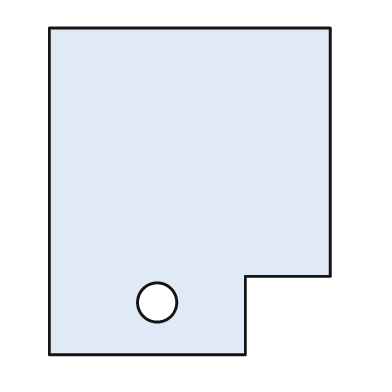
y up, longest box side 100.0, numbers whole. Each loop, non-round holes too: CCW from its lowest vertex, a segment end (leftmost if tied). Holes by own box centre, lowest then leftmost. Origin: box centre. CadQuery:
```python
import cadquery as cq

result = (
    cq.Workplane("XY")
    .moveTo(-43.0, -50.0)
    .lineTo(17.0, -50.0)
    .lineTo(17.0, -26.0)
    .lineTo(43.0, -26.0)
    .lineTo(43.0, 50.0)
    .lineTo(-43.0, 50.0)
    .close()
    .moveTo(-10.0, -34.0)
    .circle(6.0)
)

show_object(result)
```